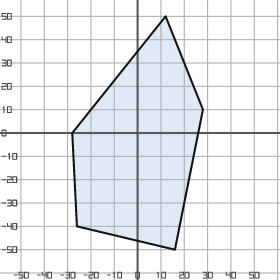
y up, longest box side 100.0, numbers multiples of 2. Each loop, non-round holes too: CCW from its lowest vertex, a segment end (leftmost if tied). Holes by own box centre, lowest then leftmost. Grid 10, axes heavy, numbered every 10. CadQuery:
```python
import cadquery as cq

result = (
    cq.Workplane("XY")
    .moveTo(16.0, -50.0)
    .lineTo(28.0, 10.0)
    .lineTo(12.0, 50.0)
    .lineTo(-28.0, 0.0)
    .lineTo(-26.0, -40.0)
    .close()
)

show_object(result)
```